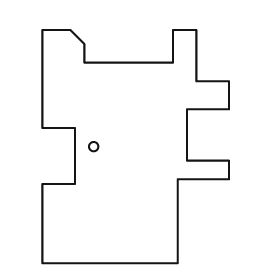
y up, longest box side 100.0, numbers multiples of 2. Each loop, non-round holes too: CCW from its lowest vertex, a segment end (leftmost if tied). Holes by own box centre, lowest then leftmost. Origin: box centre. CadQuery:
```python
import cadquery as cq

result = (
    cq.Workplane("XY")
    .moveTo(-40.0, -50.0)
    .lineTo(18.0, -50.0)
    .lineTo(18.0, -14.0)
    .lineTo(40.0, -14.0)
    .lineTo(40.0, -6.0)
    .lineTo(22.0, -6.0)
    .lineTo(22.0, 16.0)
    .lineTo(40.0, 16.0)
    .lineTo(40.0, 28.0)
    .lineTo(26.0, 28.0)
    .lineTo(26.0, 50.0)
    .lineTo(16.0, 50.0)
    .lineTo(16.0, 36.0)
    .lineTo(-22.0, 36.0)
    .lineTo(-22.0, 44.0)
    .lineTo(-28.0, 50.0)
    .lineTo(-40.0, 50.0)
    .lineTo(-40.0, 8.0)
    .lineTo(-26.0, 8.0)
    .lineTo(-26.0, -16.0)
    .lineTo(-40.0, -16.0)
    .close()
    .moveTo(-18.0, 0.0)
    .circle(2.0)
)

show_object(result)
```